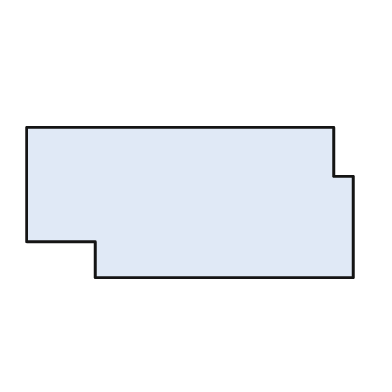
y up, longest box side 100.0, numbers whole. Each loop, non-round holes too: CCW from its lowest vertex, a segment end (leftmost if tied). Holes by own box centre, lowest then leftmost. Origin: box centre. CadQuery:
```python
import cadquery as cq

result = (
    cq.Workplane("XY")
    .moveTo(-29.0, -23.0)
    .lineTo(50.0, -23.0)
    .lineTo(50.0, 8.0)
    .lineTo(44.0, 8.0)
    .lineTo(44.0, 23.0)
    .lineTo(-50.0, 23.0)
    .lineTo(-50.0, -12.0)
    .lineTo(-29.0, -12.0)
    .close()
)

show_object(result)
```